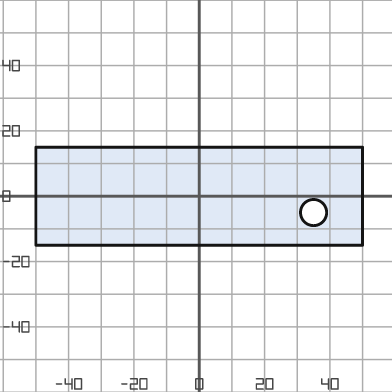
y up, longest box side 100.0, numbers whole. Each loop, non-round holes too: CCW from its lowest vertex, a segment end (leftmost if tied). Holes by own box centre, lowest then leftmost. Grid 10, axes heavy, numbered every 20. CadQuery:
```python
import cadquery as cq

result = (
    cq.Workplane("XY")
    .moveTo(-50.0, -15.0)
    .lineTo(50.0, -15.0)
    .lineTo(50.0, 15.0)
    .lineTo(-50.0, 15.0)
    .close()
    .moveTo(35.0, -5.0)
    .circle(4.0)
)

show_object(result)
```